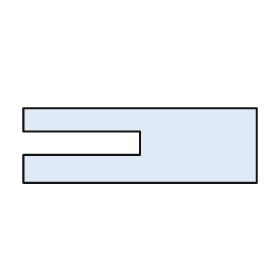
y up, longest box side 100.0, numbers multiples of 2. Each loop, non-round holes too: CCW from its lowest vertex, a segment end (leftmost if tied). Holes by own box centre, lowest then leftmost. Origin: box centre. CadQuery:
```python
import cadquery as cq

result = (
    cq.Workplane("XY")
    .moveTo(-50.0, -16.0)
    .lineTo(50.0, -16.0)
    .lineTo(50.0, 16.0)
    .lineTo(-50.0, 16.0)
    .lineTo(-50.0, 6.0)
    .lineTo(0.0, 6.0)
    .lineTo(0.0, -4.0)
    .lineTo(-50.0, -4.0)
    .close()
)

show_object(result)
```